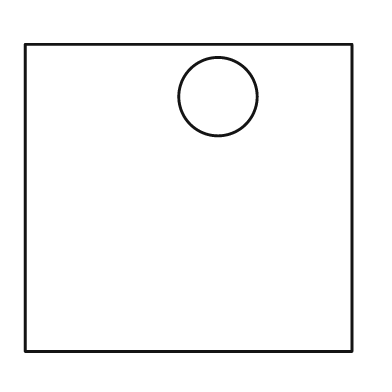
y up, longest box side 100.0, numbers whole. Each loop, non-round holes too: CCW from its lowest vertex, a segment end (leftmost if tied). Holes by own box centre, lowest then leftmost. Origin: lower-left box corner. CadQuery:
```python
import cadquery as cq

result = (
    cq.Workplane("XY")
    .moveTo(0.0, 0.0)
    .lineTo(100.0, 0.0)
    .lineTo(100.0, 94.0)
    .lineTo(0.0, 94.0)
    .close()
    .moveTo(59.0, 78.0)
    .circle(12.0)
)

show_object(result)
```